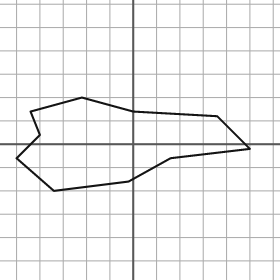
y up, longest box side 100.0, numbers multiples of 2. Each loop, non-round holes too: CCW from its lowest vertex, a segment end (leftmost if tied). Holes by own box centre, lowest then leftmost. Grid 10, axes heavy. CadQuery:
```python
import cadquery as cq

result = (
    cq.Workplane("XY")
    .moveTo(-34.0, -20.0)
    .lineTo(-2.0, -16.0)
    .lineTo(16.0, -6.0)
    .lineTo(50.0, -2.0)
    .lineTo(36.0, 12.0)
    .lineTo(0.0, 14.0)
    .lineTo(-22.0, 20.0)
    .lineTo(-44.0, 14.0)
    .lineTo(-40.0, 4.0)
    .lineTo(-50.0, -6.0)
    .close()
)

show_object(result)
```